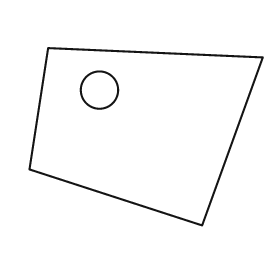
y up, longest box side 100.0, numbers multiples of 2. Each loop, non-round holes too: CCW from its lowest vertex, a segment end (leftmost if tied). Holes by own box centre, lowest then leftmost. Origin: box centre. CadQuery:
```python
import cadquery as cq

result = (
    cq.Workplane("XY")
    .moveTo(24.0, -38.0)
    .lineTo(50.0, 34.0)
    .lineTo(-42.0, 38.0)
    .lineTo(-50.0, -14.0)
    .close()
    .moveTo(-20.0, 20.0)
    .circle(8.0)
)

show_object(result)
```